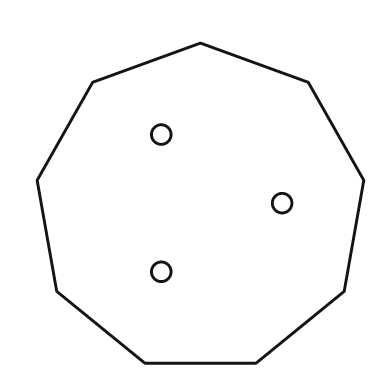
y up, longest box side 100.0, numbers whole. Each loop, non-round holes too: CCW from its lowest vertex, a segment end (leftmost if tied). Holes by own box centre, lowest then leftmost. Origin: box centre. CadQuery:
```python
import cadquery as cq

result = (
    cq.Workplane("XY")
    .moveTo(-17.0, -49.0)
    .lineTo(17.0, -49.0)
    .lineTo(44.0, -27.0)
    .lineTo(50.0, 7.0)
    .lineTo(33.0, 37.0)
    .lineTo(0.0, 49.0)
    .lineTo(-33.0, 37.0)
    .lineTo(-50.0, 7.0)
    .lineTo(-44.0, -27.0)
    .close()
    .moveTo(-12.0, -21.0)
    .circle(3.0)
    .moveTo(25.0, 0.0)
    .circle(3.0)
    .moveTo(-12.0, 21.0)
    .circle(3.0)
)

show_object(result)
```